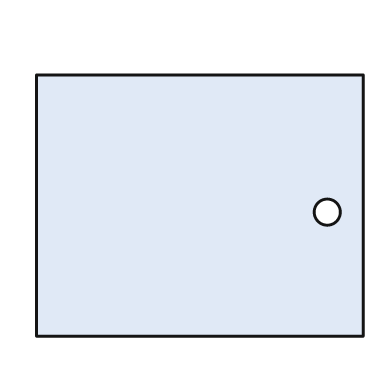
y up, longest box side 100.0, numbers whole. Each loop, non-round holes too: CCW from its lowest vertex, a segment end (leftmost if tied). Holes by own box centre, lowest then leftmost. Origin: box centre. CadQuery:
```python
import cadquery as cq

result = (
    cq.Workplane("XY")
    .moveTo(-50.0, -40.0)
    .lineTo(50.0, -40.0)
    .lineTo(50.0, 40.0)
    .lineTo(-50.0, 40.0)
    .close()
    .moveTo(39.0, -2.0)
    .circle(4.0)
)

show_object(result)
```